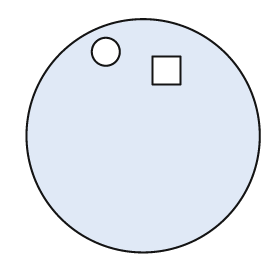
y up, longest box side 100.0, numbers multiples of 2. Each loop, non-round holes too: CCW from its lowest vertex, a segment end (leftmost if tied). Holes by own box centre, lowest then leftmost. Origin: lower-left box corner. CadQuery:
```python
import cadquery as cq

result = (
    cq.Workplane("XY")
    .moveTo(50.0, 50.0)
    .circle(50.0)
    .moveTo(54.0, 72.0)
    .lineTo(66.0, 72.0)
    .lineTo(66.0, 84.0)
    .lineTo(54.0, 84.0)
    .close()
    .moveTo(34.0, 86.0)
    .circle(6.0)
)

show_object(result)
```